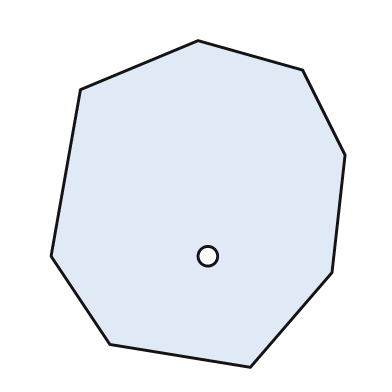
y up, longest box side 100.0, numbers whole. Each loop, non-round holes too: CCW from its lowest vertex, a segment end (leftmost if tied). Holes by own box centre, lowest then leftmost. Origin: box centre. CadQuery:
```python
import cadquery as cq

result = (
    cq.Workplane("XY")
    .moveTo(16.0, -50.0)
    .lineTo(41.0, -21.0)
    .lineTo(45.0, 15.0)
    .lineTo(32.0, 41.0)
    .lineTo(0.0, 50.0)
    .lineTo(-36.0, 35.0)
    .lineTo(-45.0, -16.0)
    .lineTo(-27.0, -43.0)
    .close()
    .moveTo(3.0, -16.0)
    .circle(3.0)
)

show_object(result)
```